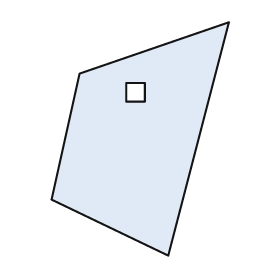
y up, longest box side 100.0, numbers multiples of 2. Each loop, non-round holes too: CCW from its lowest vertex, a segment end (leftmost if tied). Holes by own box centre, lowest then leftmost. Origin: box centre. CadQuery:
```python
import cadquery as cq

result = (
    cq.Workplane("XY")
    .moveTo(12.0, -50.0)
    .lineTo(38.0, 50.0)
    .lineTo(-26.0, 28.0)
    .lineTo(-38.0, -26.0)
    .close()
    .moveTo(-6.0, 16.0)
    .lineTo(2.0, 16.0)
    .lineTo(2.0, 24.0)
    .lineTo(-6.0, 24.0)
    .close()
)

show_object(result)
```